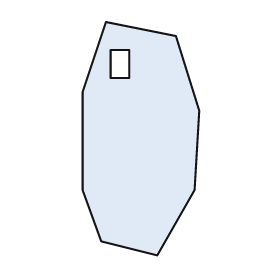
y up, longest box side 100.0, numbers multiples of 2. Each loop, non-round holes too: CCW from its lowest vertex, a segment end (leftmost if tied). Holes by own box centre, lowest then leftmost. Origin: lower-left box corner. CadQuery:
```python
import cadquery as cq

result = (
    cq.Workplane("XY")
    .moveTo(32.0, 0.0)
    .lineTo(48.0, 28.0)
    .lineTo(50.0, 62.0)
    .lineTo(40.0, 94.0)
    .lineTo(10.0, 100.0)
    .lineTo(0.0, 70.0)
    .lineTo(0.0, 28.0)
    .lineTo(8.0, 6.0)
    .close()
    .moveTo(12.0, 76.0)
    .lineTo(20.0, 76.0)
    .lineTo(20.0, 88.0)
    .lineTo(12.0, 88.0)
    .close()
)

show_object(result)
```